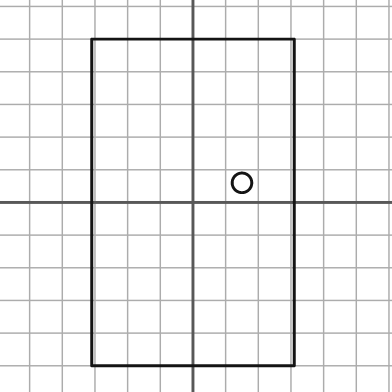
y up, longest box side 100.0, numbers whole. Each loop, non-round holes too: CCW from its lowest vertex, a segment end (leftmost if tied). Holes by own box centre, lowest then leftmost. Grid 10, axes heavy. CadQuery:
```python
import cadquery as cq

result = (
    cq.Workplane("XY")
    .moveTo(-31.0, -50.0)
    .lineTo(31.0, -50.0)
    .lineTo(31.0, 50.0)
    .lineTo(-31.0, 50.0)
    .close()
    .moveTo(15.0, 6.0)
    .circle(3.0)
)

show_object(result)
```